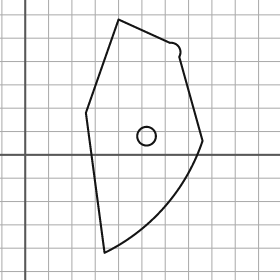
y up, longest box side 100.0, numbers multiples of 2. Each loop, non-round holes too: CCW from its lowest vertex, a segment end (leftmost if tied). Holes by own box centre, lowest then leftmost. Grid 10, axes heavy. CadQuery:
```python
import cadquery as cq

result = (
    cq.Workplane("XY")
    .moveTo(34.0, -42.0)
    .threePointArc((60.0, -22.0), (76.0, 6.0))
    .lineTo(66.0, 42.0)
    .threePointArc((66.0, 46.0), (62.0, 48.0))
    .lineTo(40.0, 58.0)
    .lineTo(26.0, 18.0)
    .close()
    .moveTo(52.0, 8.0)
    .circle(4.0)
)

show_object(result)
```